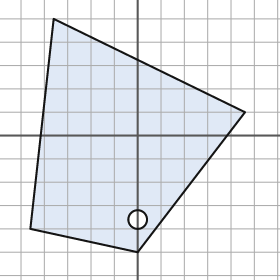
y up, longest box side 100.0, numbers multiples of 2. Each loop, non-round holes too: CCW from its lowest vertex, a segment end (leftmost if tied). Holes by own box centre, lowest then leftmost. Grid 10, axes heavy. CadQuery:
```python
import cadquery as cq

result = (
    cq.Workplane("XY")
    .moveTo(0.0, -50.0)
    .lineTo(46.0, 10.0)
    .lineTo(-36.0, 50.0)
    .lineTo(-46.0, -40.0)
    .close()
    .moveTo(0.0, -36.0)
    .circle(4.0)
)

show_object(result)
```